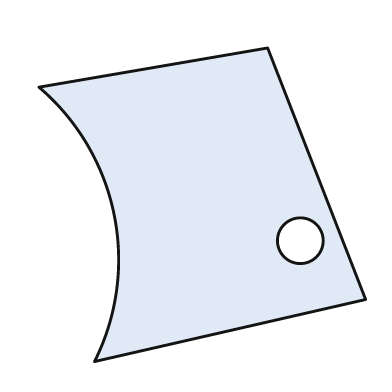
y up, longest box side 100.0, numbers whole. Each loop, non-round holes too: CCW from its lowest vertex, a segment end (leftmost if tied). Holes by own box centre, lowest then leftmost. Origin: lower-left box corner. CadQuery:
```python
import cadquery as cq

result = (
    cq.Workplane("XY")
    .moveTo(17.0, 0.0)
    .lineTo(100.0, 19.0)
    .lineTo(70.0, 96.0)
    .lineTo(0.0, 84.0)
    .threePointArc((23.0, 45.0), (17.0, 0.0))
    .close()
    .moveTo(80.0, 37.0)
    .circle(7.0)
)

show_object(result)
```